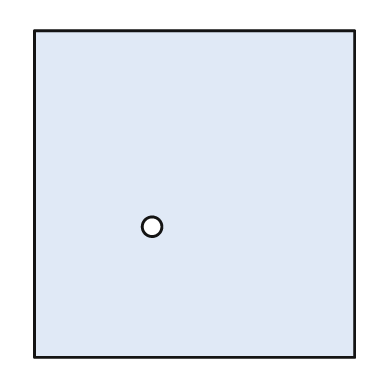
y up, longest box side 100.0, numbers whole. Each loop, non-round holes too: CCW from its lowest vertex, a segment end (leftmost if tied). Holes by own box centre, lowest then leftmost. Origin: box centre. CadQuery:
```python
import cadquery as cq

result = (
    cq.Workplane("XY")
    .moveTo(-49.0, -50.0)
    .lineTo(49.0, -50.0)
    .lineTo(49.0, 50.0)
    .lineTo(-49.0, 50.0)
    .close()
    .moveTo(-13.0, -10.0)
    .circle(3.0)
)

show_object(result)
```